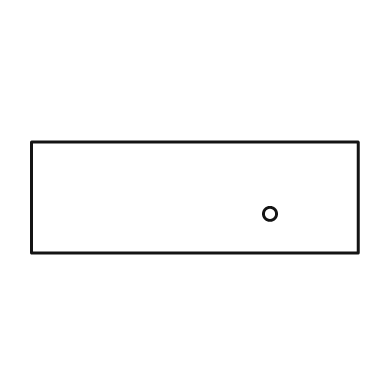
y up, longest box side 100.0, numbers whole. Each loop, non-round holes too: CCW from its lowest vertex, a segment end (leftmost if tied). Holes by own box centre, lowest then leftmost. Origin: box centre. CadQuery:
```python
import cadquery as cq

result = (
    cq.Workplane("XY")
    .moveTo(-50.0, -17.0)
    .lineTo(50.0, -17.0)
    .lineTo(50.0, 17.0)
    .lineTo(-50.0, 17.0)
    .close()
    .moveTo(23.0, -5.0)
    .circle(2.0)
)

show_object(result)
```